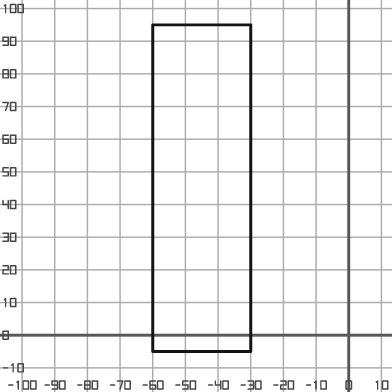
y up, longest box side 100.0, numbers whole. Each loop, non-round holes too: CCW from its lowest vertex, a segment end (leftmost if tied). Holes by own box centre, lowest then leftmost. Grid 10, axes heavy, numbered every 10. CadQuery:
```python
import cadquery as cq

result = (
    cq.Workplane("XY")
    .moveTo(-60.0, -5.0)
    .lineTo(-30.0, -5.0)
    .lineTo(-30.0, 95.0)
    .lineTo(-60.0, 95.0)
    .close()
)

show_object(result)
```